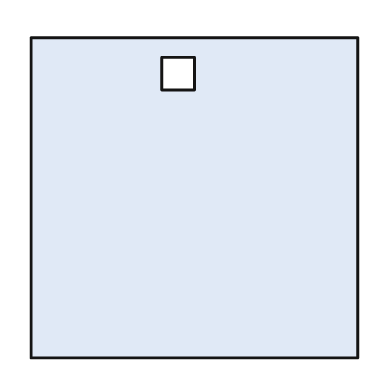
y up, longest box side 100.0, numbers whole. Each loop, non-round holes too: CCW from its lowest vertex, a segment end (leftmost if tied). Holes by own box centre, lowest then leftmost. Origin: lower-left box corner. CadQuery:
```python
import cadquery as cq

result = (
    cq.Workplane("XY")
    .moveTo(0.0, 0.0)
    .lineTo(100.0, 0.0)
    .lineTo(100.0, 98.0)
    .lineTo(0.0, 98.0)
    .close()
    .moveTo(40.0, 82.0)
    .lineTo(50.0, 82.0)
    .lineTo(50.0, 92.0)
    .lineTo(40.0, 92.0)
    .close()
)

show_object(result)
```